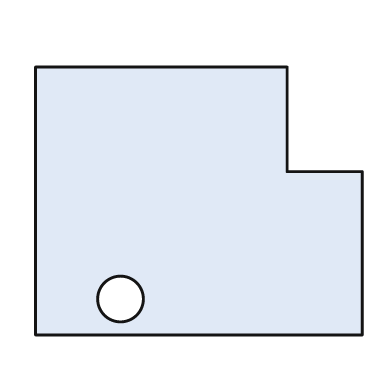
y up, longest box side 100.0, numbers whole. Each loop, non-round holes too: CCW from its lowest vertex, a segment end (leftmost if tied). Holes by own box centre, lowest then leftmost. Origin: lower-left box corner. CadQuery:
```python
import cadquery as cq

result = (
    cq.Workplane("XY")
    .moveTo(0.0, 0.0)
    .lineTo(100.0, 0.0)
    .lineTo(100.0, 50.0)
    .lineTo(77.0, 50.0)
    .lineTo(77.0, 82.0)
    .lineTo(0.0, 82.0)
    .close()
    .moveTo(26.0, 11.0)
    .circle(7.0)
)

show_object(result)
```